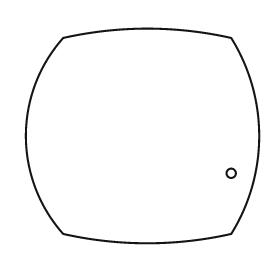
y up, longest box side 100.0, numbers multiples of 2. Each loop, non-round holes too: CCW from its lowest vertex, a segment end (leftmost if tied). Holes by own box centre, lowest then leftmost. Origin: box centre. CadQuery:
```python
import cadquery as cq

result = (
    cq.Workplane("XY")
    .moveTo(-34.0, -42.0)
    .threePointArc((2.0, -46.0), (38.0, -42.0))
    .threePointArc((50.0, 0.0), (38.0, 42.0))
    .threePointArc((2.0, 46.0), (-34.0, 42.0))
    .threePointArc((-50.0, 0.0), (-34.0, -42.0))
    .close()
    .moveTo(38.0, -16.0)
    .circle(2.0)
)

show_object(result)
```